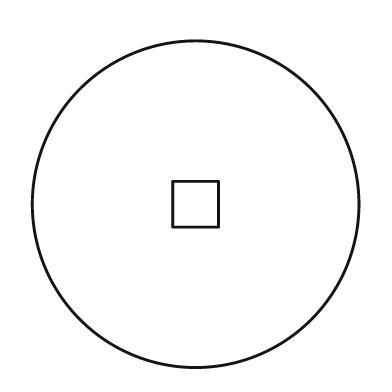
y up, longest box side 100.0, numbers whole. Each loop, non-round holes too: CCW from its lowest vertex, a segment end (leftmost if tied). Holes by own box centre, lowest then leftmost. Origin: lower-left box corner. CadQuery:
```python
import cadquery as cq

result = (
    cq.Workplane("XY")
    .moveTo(50.0, 50.0)
    .circle(50.0)
    .moveTo(43.0, 43.0)
    .lineTo(57.0, 43.0)
    .lineTo(57.0, 57.0)
    .lineTo(43.0, 57.0)
    .close()
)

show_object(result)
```